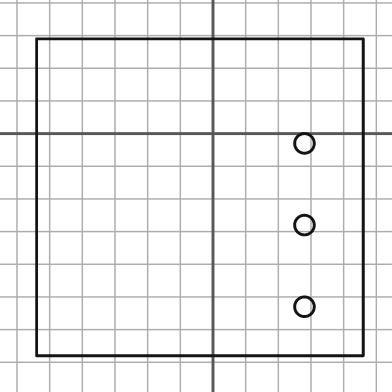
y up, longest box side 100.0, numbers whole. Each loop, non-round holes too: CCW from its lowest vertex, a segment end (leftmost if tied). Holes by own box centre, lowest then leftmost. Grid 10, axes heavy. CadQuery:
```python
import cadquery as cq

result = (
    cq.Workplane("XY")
    .moveTo(-54.0, -68.0)
    .lineTo(46.0, -68.0)
    .lineTo(46.0, 29.0)
    .lineTo(-54.0, 29.0)
    .close()
    .moveTo(28.0, -53.0)
    .circle(3.0)
    .moveTo(28.0, -28.0)
    .circle(3.0)
    .moveTo(28.0, -3.0)
    .circle(3.0)
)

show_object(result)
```